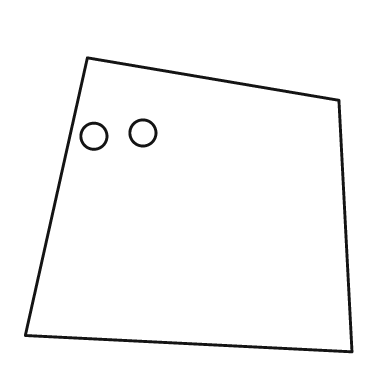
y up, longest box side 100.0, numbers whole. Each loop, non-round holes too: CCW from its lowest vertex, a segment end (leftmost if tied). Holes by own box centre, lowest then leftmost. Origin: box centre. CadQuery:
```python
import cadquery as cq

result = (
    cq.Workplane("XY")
    .moveTo(50.0, -45.0)
    .lineTo(46.0, 32.0)
    .lineTo(-31.0, 45.0)
    .lineTo(-50.0, -40.0)
    .close()
    .moveTo(-29.0, 21.0)
    .circle(4.0)
    .moveTo(-14.0, 22.0)
    .circle(4.0)
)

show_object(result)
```